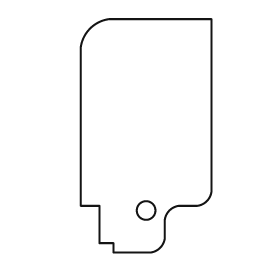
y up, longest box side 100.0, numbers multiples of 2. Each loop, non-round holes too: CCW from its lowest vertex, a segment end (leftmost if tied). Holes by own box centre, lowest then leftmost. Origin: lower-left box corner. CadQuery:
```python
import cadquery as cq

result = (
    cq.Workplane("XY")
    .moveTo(14.0, 0.0)
    .lineTo(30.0, 0.0)
    .threePointArc((34.0, 2.0), (36.0, 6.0))
    .lineTo(36.0, 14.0)
    .threePointArc((38.0, 18.0), (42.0, 20.0))
    .lineTo(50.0, 20.0)
    .threePointArc((54.0, 22.0), (56.0, 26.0))
    .lineTo(56.0, 100.0)
    .lineTo(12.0, 100.0)
    .threePointArc((4.0, 96.0), (0.0, 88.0))
    .lineTo(0.0, 20.0)
    .lineTo(8.0, 20.0)
    .lineTo(8.0, 4.0)
    .lineTo(14.0, 4.0)
    .close()
    .moveTo(28.0, 18.0)
    .circle(4.0)
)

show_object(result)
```